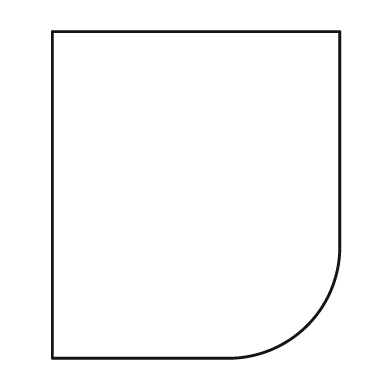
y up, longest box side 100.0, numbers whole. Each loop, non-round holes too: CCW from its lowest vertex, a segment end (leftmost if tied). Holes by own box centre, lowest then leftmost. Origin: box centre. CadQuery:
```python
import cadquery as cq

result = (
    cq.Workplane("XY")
    .moveTo(-44.0, -50.0)
    .lineTo(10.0, -50.0)
    .threePointArc((34.0, -40.0), (44.0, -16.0))
    .lineTo(44.0, 50.0)
    .lineTo(-44.0, 50.0)
    .close()
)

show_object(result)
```